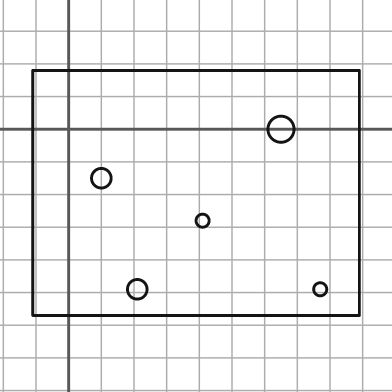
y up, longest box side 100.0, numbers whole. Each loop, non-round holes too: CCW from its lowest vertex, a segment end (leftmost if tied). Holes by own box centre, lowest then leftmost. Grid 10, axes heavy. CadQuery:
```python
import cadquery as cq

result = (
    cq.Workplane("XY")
    .moveTo(-11.0, -57.0)
    .lineTo(89.0, -57.0)
    .lineTo(89.0, 18.0)
    .lineTo(-11.0, 18.0)
    .close()
    .moveTo(21.0, -49.0)
    .circle(3.0)
    .moveTo(77.0, -49.0)
    .circle(2.0)
    .moveTo(41.0, -28.0)
    .circle(2.0)
    .moveTo(10.0, -15.0)
    .circle(3.0)
    .moveTo(65.0, 0.0)
    .circle(4.0)
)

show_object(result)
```